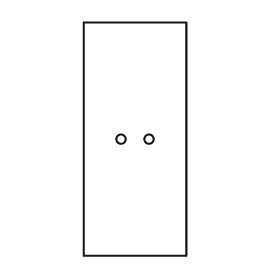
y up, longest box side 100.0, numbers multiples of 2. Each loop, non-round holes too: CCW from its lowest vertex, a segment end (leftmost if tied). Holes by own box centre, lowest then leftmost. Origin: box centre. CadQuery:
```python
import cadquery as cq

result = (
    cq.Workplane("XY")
    .moveTo(-22.0, -50.0)
    .lineTo(22.0, -50.0)
    .lineTo(22.0, 50.0)
    .lineTo(-22.0, 50.0)
    .close()
    .moveTo(-6.0, 0.0)
    .circle(2.0)
    .moveTo(6.0, 0.0)
    .circle(2.0)
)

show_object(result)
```